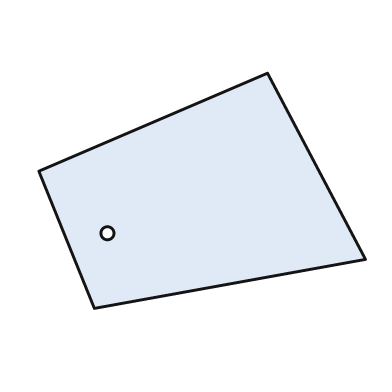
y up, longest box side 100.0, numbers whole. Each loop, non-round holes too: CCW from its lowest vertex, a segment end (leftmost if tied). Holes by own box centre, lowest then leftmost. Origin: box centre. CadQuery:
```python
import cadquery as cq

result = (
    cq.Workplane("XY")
    .moveTo(-33.0, -36.0)
    .lineTo(50.0, -21.0)
    .lineTo(20.0, 36.0)
    .lineTo(-50.0, 6.0)
    .close()
    .moveTo(-29.0, -13.0)
    .circle(2.0)
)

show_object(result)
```